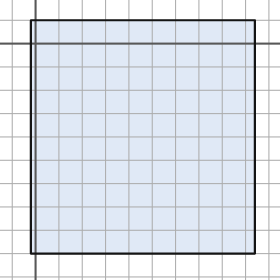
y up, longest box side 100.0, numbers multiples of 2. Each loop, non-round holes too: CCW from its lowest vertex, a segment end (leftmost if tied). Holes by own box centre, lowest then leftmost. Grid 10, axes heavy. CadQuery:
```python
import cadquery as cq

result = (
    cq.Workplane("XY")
    .moveTo(-2.0, -90.0)
    .lineTo(94.0, -90.0)
    .lineTo(94.0, 10.0)
    .lineTo(-2.0, 10.0)
    .close()
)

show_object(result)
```